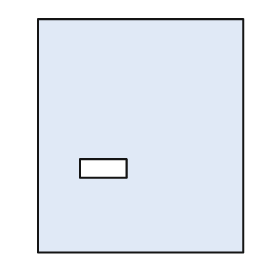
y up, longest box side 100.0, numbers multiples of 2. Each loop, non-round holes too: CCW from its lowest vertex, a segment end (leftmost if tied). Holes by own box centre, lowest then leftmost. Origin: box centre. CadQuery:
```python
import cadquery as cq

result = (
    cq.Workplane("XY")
    .moveTo(-44.0, -50.0)
    .lineTo(44.0, -50.0)
    .lineTo(44.0, 50.0)
    .lineTo(-44.0, 50.0)
    .close()
    .moveTo(-26.0, -18.0)
    .lineTo(-6.0, -18.0)
    .lineTo(-6.0, -10.0)
    .lineTo(-26.0, -10.0)
    .close()
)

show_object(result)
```